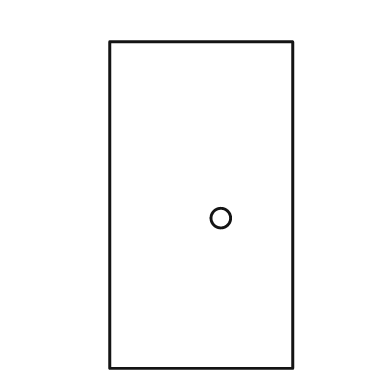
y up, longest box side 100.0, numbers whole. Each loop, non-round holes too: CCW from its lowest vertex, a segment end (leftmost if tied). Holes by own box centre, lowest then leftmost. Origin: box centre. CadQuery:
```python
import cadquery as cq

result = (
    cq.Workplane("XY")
    .moveTo(-28.0, -50.0)
    .lineTo(28.0, -50.0)
    .lineTo(28.0, 50.0)
    .lineTo(-28.0, 50.0)
    .close()
    .moveTo(6.0, -4.0)
    .circle(3.0)
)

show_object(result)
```